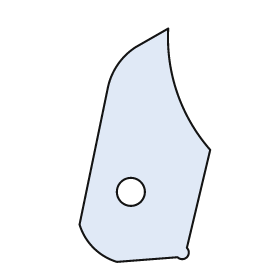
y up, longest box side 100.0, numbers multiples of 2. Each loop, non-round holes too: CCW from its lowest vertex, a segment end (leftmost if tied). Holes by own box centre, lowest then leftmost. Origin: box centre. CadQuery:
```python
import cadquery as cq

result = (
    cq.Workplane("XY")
    .moveTo(-12.0, -50.0)
    .lineTo(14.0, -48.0)
    .threePointArc((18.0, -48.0), (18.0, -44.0))
    .lineTo(28.0, -2.0)
    .threePointArc((14.0, 22.0), (10.0, 50.0))
    .lineTo(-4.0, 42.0)
    .threePointArc((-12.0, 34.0), (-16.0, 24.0))
    .lineTo(-28.0, -34.0)
    .threePointArc((-22.0, -44.0), (-12.0, -50.0))
    .close()
    .moveTo(-6.0, -20.0)
    .circle(6.0)
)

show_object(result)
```